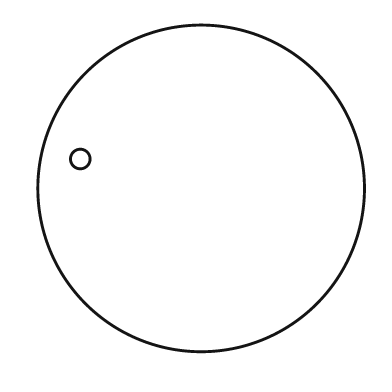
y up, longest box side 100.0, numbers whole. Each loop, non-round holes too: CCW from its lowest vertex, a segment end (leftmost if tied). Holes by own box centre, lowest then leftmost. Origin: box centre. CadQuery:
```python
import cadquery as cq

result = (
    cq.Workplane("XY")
    .moveTo(0.0, 0.0)
    .circle(50.0)
    .moveTo(-37.0, 9.0)
    .circle(3.0)
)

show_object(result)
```